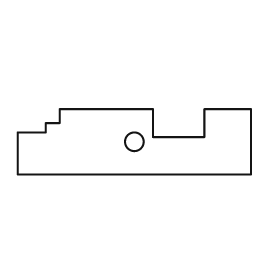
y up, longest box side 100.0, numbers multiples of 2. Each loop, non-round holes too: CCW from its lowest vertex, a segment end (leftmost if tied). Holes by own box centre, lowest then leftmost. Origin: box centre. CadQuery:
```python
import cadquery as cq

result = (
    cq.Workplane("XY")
    .moveTo(-50.0, -14.0)
    .lineTo(50.0, -14.0)
    .lineTo(50.0, 14.0)
    .lineTo(30.0, 14.0)
    .lineTo(30.0, 2.0)
    .lineTo(8.0, 2.0)
    .lineTo(8.0, 14.0)
    .lineTo(-32.0, 14.0)
    .lineTo(-32.0, 8.0)
    .lineTo(-38.0, 8.0)
    .lineTo(-38.0, 4.0)
    .lineTo(-50.0, 4.0)
    .close()
    .moveTo(0.0, 0.0)
    .circle(4.0)
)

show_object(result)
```